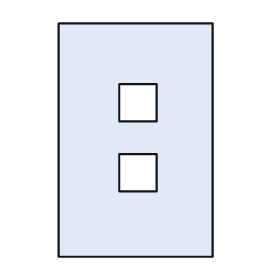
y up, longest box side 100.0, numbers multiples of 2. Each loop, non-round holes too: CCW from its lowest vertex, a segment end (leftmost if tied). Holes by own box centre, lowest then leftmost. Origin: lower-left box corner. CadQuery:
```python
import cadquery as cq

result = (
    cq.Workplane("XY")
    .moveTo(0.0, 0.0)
    .lineTo(66.0, 0.0)
    .lineTo(66.0, 100.0)
    .lineTo(0.0, 100.0)
    .close()
    .moveTo(26.0, 28.0)
    .lineTo(42.0, 28.0)
    .lineTo(42.0, 44.0)
    .lineTo(26.0, 44.0)
    .close()
    .moveTo(26.0, 58.0)
    .lineTo(42.0, 58.0)
    .lineTo(42.0, 74.0)
    .lineTo(26.0, 74.0)
    .close()
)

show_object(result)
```